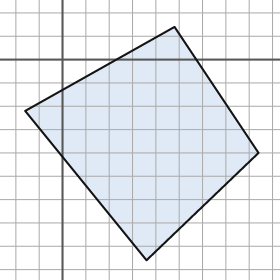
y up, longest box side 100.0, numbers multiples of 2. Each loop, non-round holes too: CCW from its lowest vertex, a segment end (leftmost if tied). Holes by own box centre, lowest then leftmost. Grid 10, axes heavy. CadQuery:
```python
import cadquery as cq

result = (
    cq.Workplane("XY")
    .moveTo(36.0, -86.0)
    .lineTo(84.0, -40.0)
    .lineTo(48.0, 14.0)
    .lineTo(-16.0, -22.0)
    .close()
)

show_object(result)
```